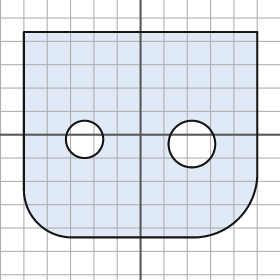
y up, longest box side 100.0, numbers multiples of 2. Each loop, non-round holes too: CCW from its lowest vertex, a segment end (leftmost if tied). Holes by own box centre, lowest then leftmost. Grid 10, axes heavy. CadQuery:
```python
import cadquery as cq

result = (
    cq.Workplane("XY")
    .moveTo(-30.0, -44.0)
    .lineTo(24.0, -44.0)
    .threePointArc((42.0, -36.0), (50.0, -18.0))
    .lineTo(50.0, 44.0)
    .lineTo(-50.0, 44.0)
    .lineTo(-50.0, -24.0)
    .threePointArc((-44.0, -38.0), (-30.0, -44.0))
    .close()
    .moveTo(22.0, -4.0)
    .circle(10.0)
    .moveTo(-24.0, -2.0)
    .circle(8.0)
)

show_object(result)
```